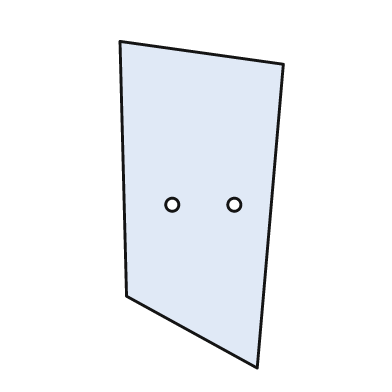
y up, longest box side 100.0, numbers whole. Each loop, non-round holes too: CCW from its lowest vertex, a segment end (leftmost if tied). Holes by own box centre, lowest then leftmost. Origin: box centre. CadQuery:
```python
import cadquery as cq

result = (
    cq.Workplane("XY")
    .moveTo(17.0, -50.0)
    .lineTo(25.0, 43.0)
    .lineTo(-25.0, 50.0)
    .lineTo(-23.0, -28.0)
    .close()
    .moveTo(-9.0, 0.0)
    .circle(2.0)
    .moveTo(10.0, 0.0)
    .circle(2.0)
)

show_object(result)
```